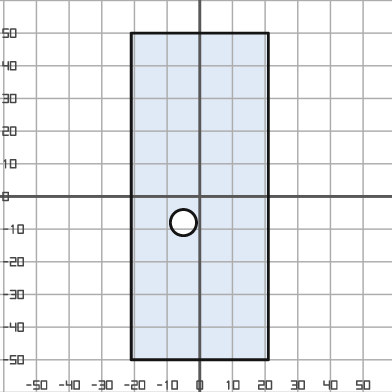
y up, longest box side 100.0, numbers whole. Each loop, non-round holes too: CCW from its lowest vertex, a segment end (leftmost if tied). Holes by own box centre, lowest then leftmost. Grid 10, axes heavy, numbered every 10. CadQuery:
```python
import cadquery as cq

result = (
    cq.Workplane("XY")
    .moveTo(-21.0, -50.0)
    .lineTo(21.0, -50.0)
    .lineTo(21.0, 50.0)
    .lineTo(-21.0, 50.0)
    .close()
    .moveTo(-5.0, -8.0)
    .circle(4.0)
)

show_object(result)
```